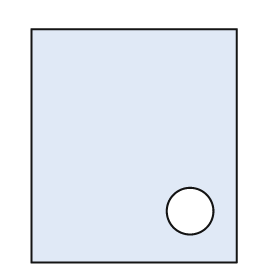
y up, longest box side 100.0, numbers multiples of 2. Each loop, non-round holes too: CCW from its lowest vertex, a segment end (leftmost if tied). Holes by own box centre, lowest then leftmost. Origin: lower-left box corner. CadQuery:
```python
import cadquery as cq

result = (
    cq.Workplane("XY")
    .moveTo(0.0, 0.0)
    .lineTo(88.0, 0.0)
    .lineTo(88.0, 100.0)
    .lineTo(0.0, 100.0)
    .close()
    .moveTo(68.0, 22.0)
    .circle(10.0)
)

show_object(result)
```